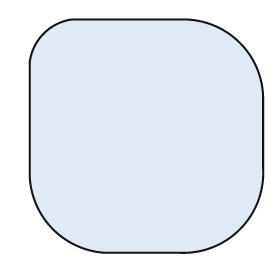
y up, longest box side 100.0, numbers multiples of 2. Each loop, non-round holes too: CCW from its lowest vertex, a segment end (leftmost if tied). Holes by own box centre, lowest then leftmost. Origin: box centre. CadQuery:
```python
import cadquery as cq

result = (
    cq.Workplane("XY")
    .moveTo(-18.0, -50.0)
    .lineTo(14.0, -50.0)
    .threePointArc((40.0, -40.0), (50.0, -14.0))
    .lineTo(50.0, 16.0)
    .threePointArc((40.0, 40.0), (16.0, 50.0))
    .lineTo(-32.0, 50.0)
    .threePointArc((-44.0, 44.0), (-50.0, 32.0))
    .lineTo(-50.0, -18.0)
    .threePointArc((-40.0, -40.0), (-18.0, -50.0))
    .close()
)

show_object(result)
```